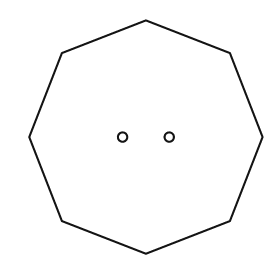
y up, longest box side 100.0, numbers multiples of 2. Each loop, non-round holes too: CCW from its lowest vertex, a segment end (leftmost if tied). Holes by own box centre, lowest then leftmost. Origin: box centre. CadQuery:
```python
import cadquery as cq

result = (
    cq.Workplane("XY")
    .moveTo(0.0, -50.0)
    .lineTo(36.0, -36.0)
    .lineTo(50.0, 0.0)
    .lineTo(36.0, 36.0)
    .lineTo(0.0, 50.0)
    .lineTo(-36.0, 36.0)
    .lineTo(-50.0, 0.0)
    .lineTo(-36.0, -36.0)
    .close()
    .moveTo(-10.0, 0.0)
    .circle(2.0)
    .moveTo(10.0, 0.0)
    .circle(2.0)
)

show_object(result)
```